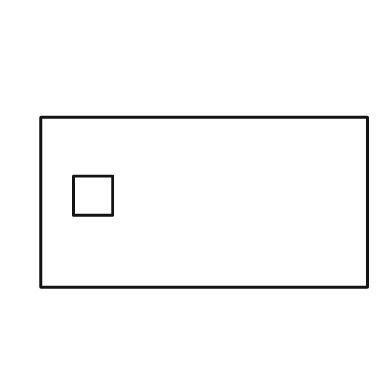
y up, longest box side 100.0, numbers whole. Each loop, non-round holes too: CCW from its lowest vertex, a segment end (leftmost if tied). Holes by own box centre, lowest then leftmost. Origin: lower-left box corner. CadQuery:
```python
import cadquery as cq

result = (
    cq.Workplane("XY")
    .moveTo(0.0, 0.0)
    .lineTo(100.0, 0.0)
    .lineTo(100.0, 52.0)
    .lineTo(0.0, 52.0)
    .close()
    .moveTo(10.0, 22.0)
    .lineTo(22.0, 22.0)
    .lineTo(22.0, 34.0)
    .lineTo(10.0, 34.0)
    .close()
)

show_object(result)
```